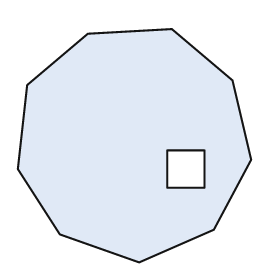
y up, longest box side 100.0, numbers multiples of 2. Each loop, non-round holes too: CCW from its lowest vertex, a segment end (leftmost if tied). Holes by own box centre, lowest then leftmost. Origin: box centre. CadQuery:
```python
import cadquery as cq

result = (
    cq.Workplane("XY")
    .moveTo(2.0, -50.0)
    .lineTo(34.0, -36.0)
    .lineTo(50.0, -6.0)
    .lineTo(42.0, 28.0)
    .lineTo(16.0, 50.0)
    .lineTo(-20.0, 48.0)
    .lineTo(-46.0, 26.0)
    .lineTo(-50.0, -10.0)
    .lineTo(-32.0, -38.0)
    .close()
    .moveTo(14.0, -18.0)
    .lineTo(30.0, -18.0)
    .lineTo(30.0, -2.0)
    .lineTo(14.0, -2.0)
    .close()
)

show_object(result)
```